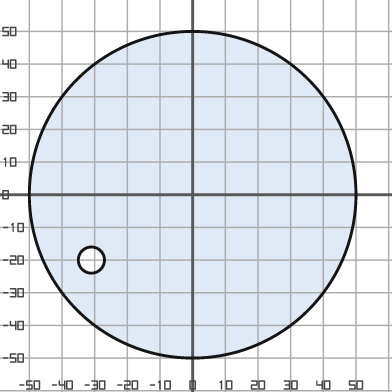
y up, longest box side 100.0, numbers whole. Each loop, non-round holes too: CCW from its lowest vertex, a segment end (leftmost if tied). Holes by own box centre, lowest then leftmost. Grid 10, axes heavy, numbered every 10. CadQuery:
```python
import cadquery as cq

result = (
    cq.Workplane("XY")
    .moveTo(0.0, 0.0)
    .circle(50.0)
    .moveTo(-31.0, -20.0)
    .circle(4.0)
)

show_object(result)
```